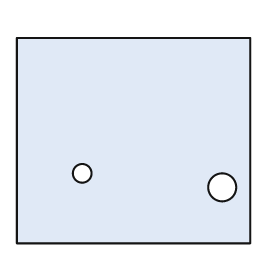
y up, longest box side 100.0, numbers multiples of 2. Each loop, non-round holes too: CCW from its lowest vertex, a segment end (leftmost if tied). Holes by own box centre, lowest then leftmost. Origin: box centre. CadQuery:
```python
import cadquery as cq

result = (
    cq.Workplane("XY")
    .moveTo(-50.0, -44.0)
    .lineTo(50.0, -44.0)
    .lineTo(50.0, 44.0)
    .lineTo(-50.0, 44.0)
    .close()
    .moveTo(38.0, -20.0)
    .circle(6.0)
    .moveTo(-22.0, -14.0)
    .circle(4.0)
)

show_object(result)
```